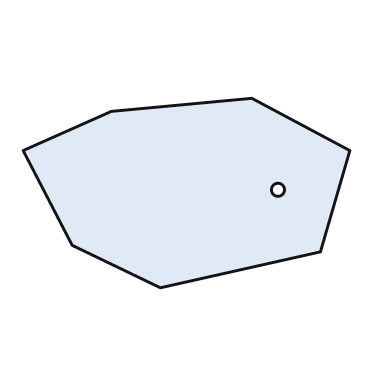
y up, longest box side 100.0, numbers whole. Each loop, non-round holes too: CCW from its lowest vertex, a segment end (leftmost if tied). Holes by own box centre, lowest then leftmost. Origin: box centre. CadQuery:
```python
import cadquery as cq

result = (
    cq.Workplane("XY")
    .moveTo(-8.0, -29.0)
    .lineTo(41.0, -18.0)
    .lineTo(50.0, 13.0)
    .lineTo(20.0, 29.0)
    .lineTo(-23.0, 25.0)
    .lineTo(-50.0, 13.0)
    .lineTo(-35.0, -16.0)
    .close()
    .moveTo(28.0, 1.0)
    .circle(2.0)
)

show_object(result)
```